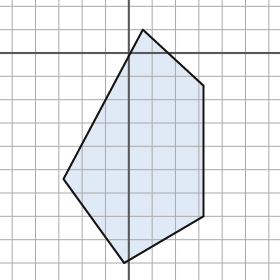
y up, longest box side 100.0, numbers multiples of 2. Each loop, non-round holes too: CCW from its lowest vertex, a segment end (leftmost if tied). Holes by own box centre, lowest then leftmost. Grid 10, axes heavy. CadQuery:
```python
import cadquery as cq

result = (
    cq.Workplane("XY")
    .moveTo(-2.0, -90.0)
    .lineTo(32.0, -70.0)
    .lineTo(32.0, -14.0)
    .lineTo(6.0, 10.0)
    .lineTo(-28.0, -54.0)
    .close()
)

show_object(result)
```